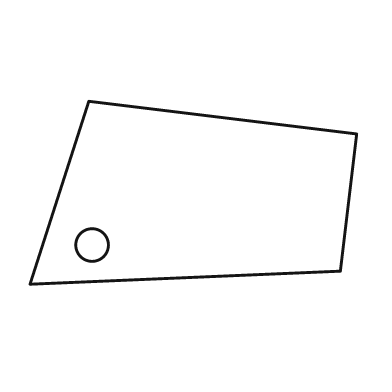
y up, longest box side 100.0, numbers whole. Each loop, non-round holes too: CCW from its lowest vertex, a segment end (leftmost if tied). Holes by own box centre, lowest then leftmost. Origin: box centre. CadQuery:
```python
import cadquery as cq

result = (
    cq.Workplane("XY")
    .moveTo(-50.0, -28.0)
    .lineTo(45.0, -24.0)
    .lineTo(50.0, 18.0)
    .lineTo(-32.0, 28.0)
    .close()
    .moveTo(-31.0, -16.0)
    .circle(5.0)
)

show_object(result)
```